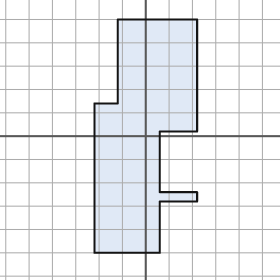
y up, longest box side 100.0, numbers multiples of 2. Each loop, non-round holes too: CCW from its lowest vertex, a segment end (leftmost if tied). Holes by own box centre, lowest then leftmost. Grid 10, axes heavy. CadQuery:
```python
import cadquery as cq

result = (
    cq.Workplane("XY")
    .moveTo(-22.0, -50.0)
    .lineTo(6.0, -50.0)
    .lineTo(6.0, -28.0)
    .lineTo(22.0, -28.0)
    .lineTo(22.0, -24.0)
    .lineTo(6.0, -24.0)
    .lineTo(6.0, 2.0)
    .lineTo(22.0, 2.0)
    .lineTo(22.0, 50.0)
    .lineTo(-12.0, 50.0)
    .lineTo(-12.0, 14.0)
    .lineTo(-22.0, 14.0)
    .close()
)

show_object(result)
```